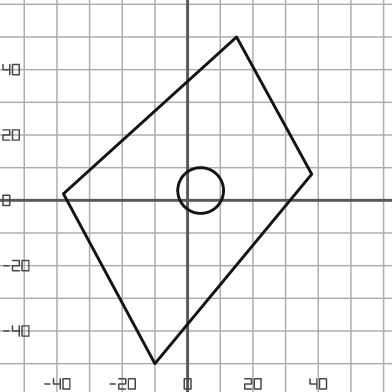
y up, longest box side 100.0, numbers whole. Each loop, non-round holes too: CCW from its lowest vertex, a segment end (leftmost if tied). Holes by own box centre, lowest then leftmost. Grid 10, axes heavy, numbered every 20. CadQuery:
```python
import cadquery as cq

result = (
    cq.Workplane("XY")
    .moveTo(-10.0, -50.0)
    .lineTo(38.0, 8.0)
    .lineTo(15.0, 50.0)
    .lineTo(-38.0, 2.0)
    .close()
    .moveTo(4.0, 3.0)
    .circle(7.0)
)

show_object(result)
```